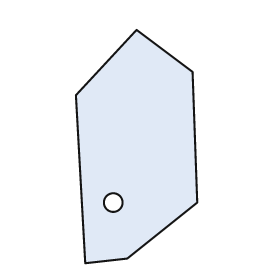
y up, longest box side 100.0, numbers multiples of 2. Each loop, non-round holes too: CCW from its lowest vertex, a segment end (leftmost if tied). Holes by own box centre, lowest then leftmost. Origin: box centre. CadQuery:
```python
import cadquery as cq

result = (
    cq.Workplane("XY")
    .moveTo(-22.0, -50.0)
    .lineTo(-4.0, -48.0)
    .lineTo(26.0, -24.0)
    .lineTo(24.0, 32.0)
    .lineTo(0.0, 50.0)
    .lineTo(-26.0, 22.0)
    .close()
    .moveTo(-10.0, -24.0)
    .circle(4.0)
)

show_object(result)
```